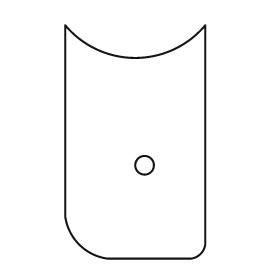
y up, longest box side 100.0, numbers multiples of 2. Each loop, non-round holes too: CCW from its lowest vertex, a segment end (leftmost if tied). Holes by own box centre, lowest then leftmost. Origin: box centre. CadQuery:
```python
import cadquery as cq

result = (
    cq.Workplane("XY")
    .moveTo(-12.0, -50.0)
    .lineTo(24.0, -50.0)
    .threePointArc((28.0, -48.0), (30.0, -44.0))
    .lineTo(30.0, 50.0)
    .threePointArc((0.0, 36.0), (-30.0, 50.0))
    .lineTo(-30.0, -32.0)
    .threePointArc((-24.0, -44.0), (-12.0, -50.0))
    .close()
    .moveTo(4.0, -10.0)
    .circle(4.0)
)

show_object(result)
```